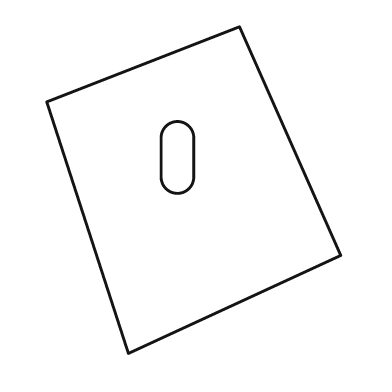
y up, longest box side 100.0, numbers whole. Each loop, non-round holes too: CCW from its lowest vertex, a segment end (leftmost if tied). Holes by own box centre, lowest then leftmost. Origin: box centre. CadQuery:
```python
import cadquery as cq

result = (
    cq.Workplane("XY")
    .moveTo(-20.0, -50.0)
    .lineTo(45.0, -20.0)
    .lineTo(14.0, 50.0)
    .lineTo(-45.0, 27.0)
    .close()
    .moveTo(-10.0, 4.0)
    .threePointArc((-5.0, -1.0), (0.0, 4.0))
    .lineTo(0.0, 16.0)
    .threePointArc((-5.0, 21.0), (-10.0, 16.0))
    .close()
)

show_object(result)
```